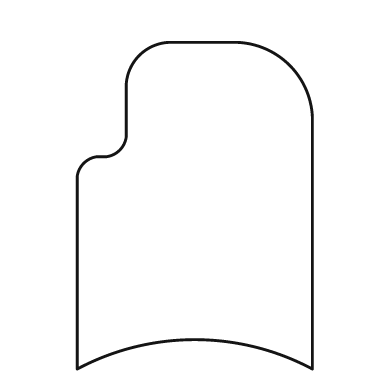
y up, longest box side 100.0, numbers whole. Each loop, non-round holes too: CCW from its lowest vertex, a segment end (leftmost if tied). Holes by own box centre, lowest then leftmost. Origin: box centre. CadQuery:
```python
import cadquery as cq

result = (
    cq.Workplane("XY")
    .moveTo(-36.0, -50.0)
    .threePointArc((0.0, -41.0), (36.0, -50.0))
    .lineTo(36.0, 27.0)
    .threePointArc((29.0, 43.0), (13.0, 50.0))
    .lineTo(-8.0, 50.0)
    .threePointArc((-17.0, 46.0), (-21.0, 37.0))
    .lineTo(-21.0, 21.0)
    .threePointArc((-23.0, 17.0), (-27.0, 15.0))
    .lineTo(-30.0, 15.0)
    .threePointArc((-34.0, 13.0), (-36.0, 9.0))
    .close()
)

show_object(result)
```